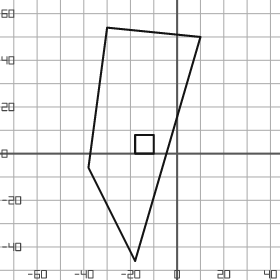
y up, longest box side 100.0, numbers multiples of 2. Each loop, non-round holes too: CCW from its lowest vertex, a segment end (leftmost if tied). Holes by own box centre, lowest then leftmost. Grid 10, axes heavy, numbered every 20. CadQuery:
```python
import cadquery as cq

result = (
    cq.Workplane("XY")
    .moveTo(-18.0, -46.0)
    .lineTo(10.0, 50.0)
    .lineTo(-30.0, 54.0)
    .lineTo(-38.0, -6.0)
    .close()
    .moveTo(-18.0, 0.0)
    .lineTo(-10.0, 0.0)
    .lineTo(-10.0, 8.0)
    .lineTo(-18.0, 8.0)
    .close()
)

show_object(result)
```